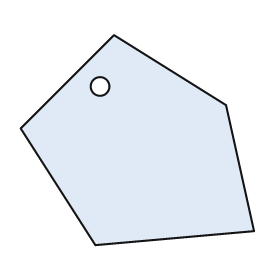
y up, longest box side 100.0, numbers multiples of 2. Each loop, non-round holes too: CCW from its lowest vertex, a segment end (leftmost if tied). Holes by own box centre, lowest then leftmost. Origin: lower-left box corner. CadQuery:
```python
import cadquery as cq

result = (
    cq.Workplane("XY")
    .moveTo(32.0, 0.0)
    .lineTo(100.0, 6.0)
    .lineTo(88.0, 60.0)
    .lineTo(40.0, 90.0)
    .lineTo(0.0, 50.0)
    .close()
    .moveTo(34.0, 68.0)
    .circle(4.0)
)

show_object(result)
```